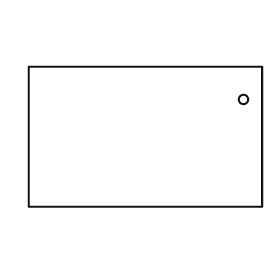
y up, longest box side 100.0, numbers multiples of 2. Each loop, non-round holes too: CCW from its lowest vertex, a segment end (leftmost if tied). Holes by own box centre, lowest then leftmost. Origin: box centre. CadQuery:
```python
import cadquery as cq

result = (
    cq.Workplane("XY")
    .moveTo(-50.0, -30.0)
    .lineTo(50.0, -30.0)
    .lineTo(50.0, 30.0)
    .lineTo(-50.0, 30.0)
    .close()
    .moveTo(42.0, 16.0)
    .circle(2.0)
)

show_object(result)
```